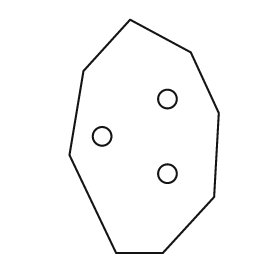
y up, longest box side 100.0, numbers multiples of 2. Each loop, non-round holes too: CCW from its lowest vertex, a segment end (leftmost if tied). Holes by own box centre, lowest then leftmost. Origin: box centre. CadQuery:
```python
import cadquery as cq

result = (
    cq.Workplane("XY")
    .moveTo(-12.0, -50.0)
    .lineTo(8.0, -50.0)
    .lineTo(30.0, -26.0)
    .lineTo(32.0, 10.0)
    .lineTo(20.0, 36.0)
    .lineTo(-6.0, 50.0)
    .lineTo(-26.0, 28.0)
    .lineTo(-32.0, -8.0)
    .close()
    .moveTo(10.0, -16.0)
    .circle(4.0)
    .moveTo(-18.0, 0.0)
    .circle(4.0)
    .moveTo(10.0, 16.0)
    .circle(4.0)
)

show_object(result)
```